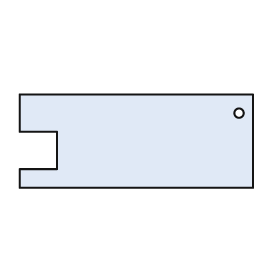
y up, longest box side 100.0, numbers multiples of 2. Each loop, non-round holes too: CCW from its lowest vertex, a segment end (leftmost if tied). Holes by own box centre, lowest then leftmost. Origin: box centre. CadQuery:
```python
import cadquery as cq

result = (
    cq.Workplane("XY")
    .moveTo(-50.0, -20.0)
    .lineTo(50.0, -20.0)
    .lineTo(50.0, 20.0)
    .lineTo(-50.0, 20.0)
    .lineTo(-50.0, 4.0)
    .lineTo(-34.0, 4.0)
    .lineTo(-34.0, -12.0)
    .lineTo(-50.0, -12.0)
    .close()
    .moveTo(44.0, 12.0)
    .circle(2.0)
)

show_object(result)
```